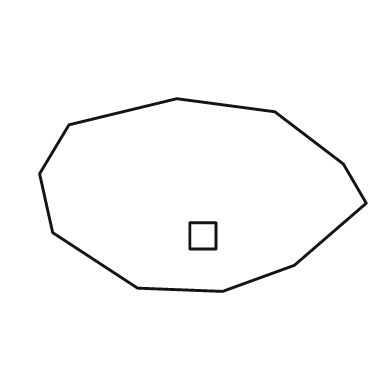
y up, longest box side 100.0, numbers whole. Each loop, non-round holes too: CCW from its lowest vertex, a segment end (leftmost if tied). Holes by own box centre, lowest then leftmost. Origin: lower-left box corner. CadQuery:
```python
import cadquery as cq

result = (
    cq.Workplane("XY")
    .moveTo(56.0, 0.0)
    .lineTo(78.0, 8.0)
    .lineTo(100.0, 27.0)
    .lineTo(93.0, 39.0)
    .lineTo(72.0, 55.0)
    .lineTo(42.0, 59.0)
    .lineTo(9.0, 51.0)
    .lineTo(0.0, 36.0)
    .lineTo(4.0, 18.0)
    .lineTo(30.0, 1.0)
    .close()
    .moveTo(46.0, 13.0)
    .lineTo(54.0, 13.0)
    .lineTo(54.0, 21.0)
    .lineTo(46.0, 21.0)
    .close()
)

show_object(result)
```